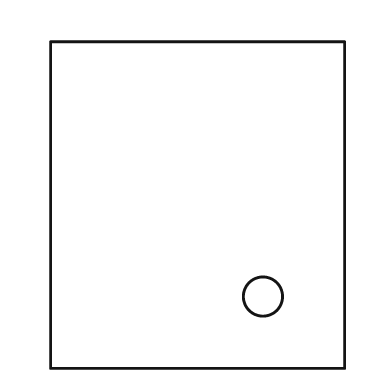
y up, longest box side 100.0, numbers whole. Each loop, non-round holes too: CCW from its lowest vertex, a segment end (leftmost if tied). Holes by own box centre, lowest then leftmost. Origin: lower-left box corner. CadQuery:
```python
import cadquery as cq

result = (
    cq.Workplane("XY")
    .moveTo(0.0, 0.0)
    .lineTo(90.0, 0.0)
    .lineTo(90.0, 100.0)
    .lineTo(0.0, 100.0)
    .close()
    .moveTo(65.0, 22.0)
    .circle(6.0)
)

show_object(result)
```